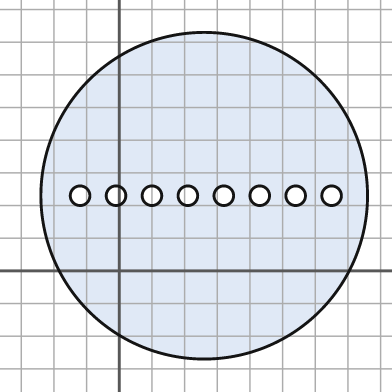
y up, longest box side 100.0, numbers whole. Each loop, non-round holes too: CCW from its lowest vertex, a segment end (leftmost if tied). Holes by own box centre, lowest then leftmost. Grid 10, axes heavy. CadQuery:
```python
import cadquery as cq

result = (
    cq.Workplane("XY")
    .moveTo(26.0, 23.0)
    .circle(50.0)
    .moveTo(-12.0, 23.0)
    .circle(3.0)
    .moveTo(-1.0, 23.0)
    .circle(3.0)
    .moveTo(10.0, 23.0)
    .circle(3.0)
    .moveTo(21.0, 23.0)
    .circle(3.0)
    .moveTo(32.0, 23.0)
    .circle(3.0)
    .moveTo(43.0, 23.0)
    .circle(3.0)
    .moveTo(54.0, 23.0)
    .circle(3.0)
    .moveTo(65.0, 23.0)
    .circle(3.0)
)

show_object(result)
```